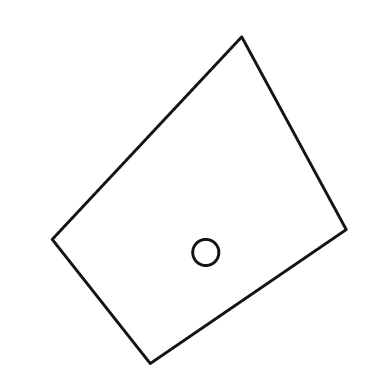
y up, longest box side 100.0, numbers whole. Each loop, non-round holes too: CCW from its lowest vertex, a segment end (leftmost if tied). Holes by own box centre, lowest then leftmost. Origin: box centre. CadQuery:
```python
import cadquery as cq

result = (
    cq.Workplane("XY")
    .moveTo(-15.0, -50.0)
    .lineTo(45.0, -9.0)
    .lineTo(13.0, 50.0)
    .lineTo(-45.0, -12.0)
    .close()
    .moveTo(2.0, -16.0)
    .circle(4.0)
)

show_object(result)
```